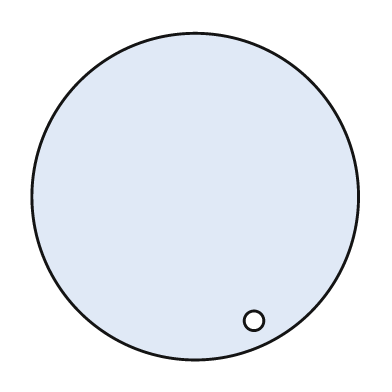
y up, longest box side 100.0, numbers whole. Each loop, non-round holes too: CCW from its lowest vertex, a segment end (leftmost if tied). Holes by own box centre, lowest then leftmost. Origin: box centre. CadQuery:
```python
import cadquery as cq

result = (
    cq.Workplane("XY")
    .moveTo(0.0, 0.0)
    .circle(50.0)
    .moveTo(18.0, -38.0)
    .circle(3.0)
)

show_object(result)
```